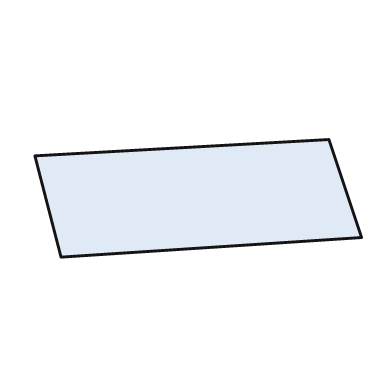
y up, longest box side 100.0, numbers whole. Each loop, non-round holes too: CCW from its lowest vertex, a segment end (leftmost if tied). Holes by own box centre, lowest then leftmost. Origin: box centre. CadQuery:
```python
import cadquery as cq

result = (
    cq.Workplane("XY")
    .moveTo(-42.0, -18.0)
    .lineTo(50.0, -12.0)
    .lineTo(40.0, 18.0)
    .lineTo(-50.0, 13.0)
    .close()
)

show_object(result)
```